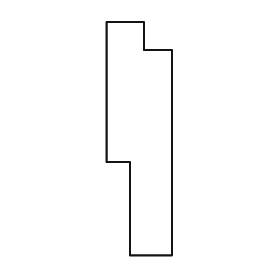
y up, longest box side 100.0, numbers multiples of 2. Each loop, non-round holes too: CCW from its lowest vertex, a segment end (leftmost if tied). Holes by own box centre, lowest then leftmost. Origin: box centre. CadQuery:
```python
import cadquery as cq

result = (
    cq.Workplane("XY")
    .moveTo(-4.0, -50.0)
    .lineTo(14.0, -50.0)
    .lineTo(14.0, 38.0)
    .lineTo(2.0, 38.0)
    .lineTo(2.0, 50.0)
    .lineTo(-14.0, 50.0)
    .lineTo(-14.0, -10.0)
    .lineTo(-4.0, -10.0)
    .close()
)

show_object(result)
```